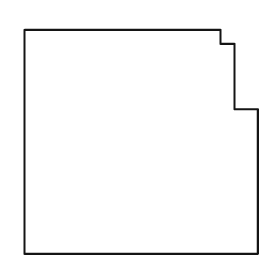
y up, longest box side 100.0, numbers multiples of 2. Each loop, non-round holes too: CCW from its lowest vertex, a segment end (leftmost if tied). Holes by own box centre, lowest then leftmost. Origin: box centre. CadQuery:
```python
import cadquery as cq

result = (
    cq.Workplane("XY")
    .moveTo(-50.0, -48.0)
    .lineTo(50.0, -48.0)
    .lineTo(50.0, 14.0)
    .lineTo(40.0, 14.0)
    .lineTo(40.0, 42.0)
    .lineTo(34.0, 42.0)
    .lineTo(34.0, 48.0)
    .lineTo(-50.0, 48.0)
    .close()
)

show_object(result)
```